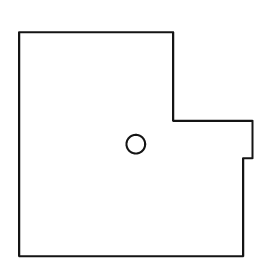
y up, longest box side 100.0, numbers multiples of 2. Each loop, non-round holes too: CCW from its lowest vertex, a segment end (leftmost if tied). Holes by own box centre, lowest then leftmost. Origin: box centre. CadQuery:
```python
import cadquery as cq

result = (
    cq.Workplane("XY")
    .moveTo(-50.0, -48.0)
    .lineTo(46.0, -48.0)
    .lineTo(46.0, -6.0)
    .lineTo(50.0, -6.0)
    .lineTo(50.0, 10.0)
    .lineTo(16.0, 10.0)
    .lineTo(16.0, 48.0)
    .lineTo(-50.0, 48.0)
    .close()
    .moveTo(0.0, 0.0)
    .circle(4.0)
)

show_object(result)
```